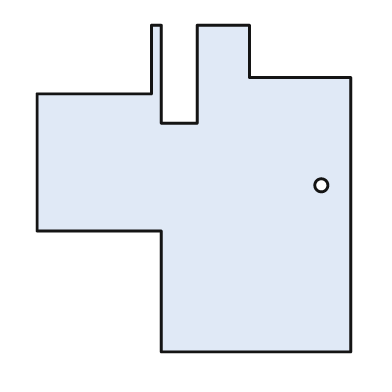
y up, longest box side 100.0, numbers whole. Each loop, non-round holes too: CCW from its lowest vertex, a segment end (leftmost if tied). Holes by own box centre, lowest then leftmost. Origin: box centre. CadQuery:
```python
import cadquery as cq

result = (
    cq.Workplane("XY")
    .moveTo(-10.0, -50.0)
    .lineTo(48.0, -50.0)
    .lineTo(48.0, 34.0)
    .lineTo(17.0, 34.0)
    .lineTo(17.0, 50.0)
    .lineTo(1.0, 50.0)
    .lineTo(1.0, 20.0)
    .lineTo(-10.0, 20.0)
    .lineTo(-10.0, 50.0)
    .lineTo(-13.0, 50.0)
    .lineTo(-13.0, 29.0)
    .lineTo(-48.0, 29.0)
    .lineTo(-48.0, -13.0)
    .lineTo(-10.0, -13.0)
    .close()
    .moveTo(39.0, 1.0)
    .circle(2.0)
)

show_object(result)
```